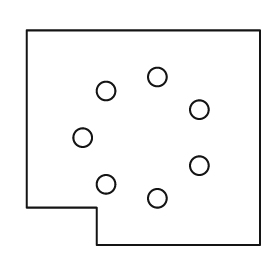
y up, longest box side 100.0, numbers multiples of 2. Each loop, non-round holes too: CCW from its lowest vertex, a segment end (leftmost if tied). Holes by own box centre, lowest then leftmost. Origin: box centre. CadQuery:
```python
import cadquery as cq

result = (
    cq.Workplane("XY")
    .moveTo(-20.0, -46.0)
    .lineTo(50.0, -46.0)
    .lineTo(50.0, 46.0)
    .lineTo(-50.0, 46.0)
    .lineTo(-50.0, -30.0)
    .lineTo(-20.0, -30.0)
    .close()
    .moveTo(6.0, -26.0)
    .circle(4.0)
    .moveTo(-16.0, -20.0)
    .circle(4.0)
    .moveTo(24.0, -12.0)
    .circle(4.0)
    .moveTo(-26.0, 0.0)
    .circle(4.0)
    .moveTo(24.0, 12.0)
    .circle(4.0)
    .moveTo(-16.0, 20.0)
    .circle(4.0)
    .moveTo(6.0, 26.0)
    .circle(4.0)
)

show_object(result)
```